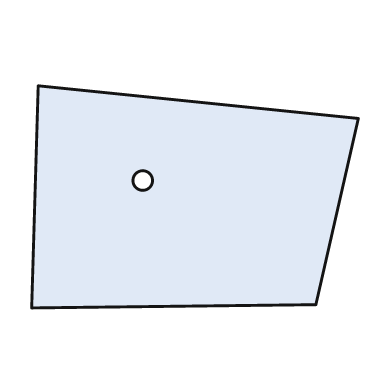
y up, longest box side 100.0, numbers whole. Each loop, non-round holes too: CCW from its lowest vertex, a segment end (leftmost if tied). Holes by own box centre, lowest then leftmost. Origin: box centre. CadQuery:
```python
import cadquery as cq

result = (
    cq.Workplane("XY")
    .moveTo(-50.0, -34.0)
    .lineTo(37.0, -33.0)
    .lineTo(50.0, 24.0)
    .lineTo(-48.0, 34.0)
    .close()
    .moveTo(-16.0, 5.0)
    .circle(3.0)
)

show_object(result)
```